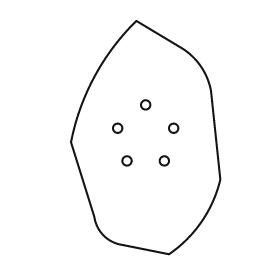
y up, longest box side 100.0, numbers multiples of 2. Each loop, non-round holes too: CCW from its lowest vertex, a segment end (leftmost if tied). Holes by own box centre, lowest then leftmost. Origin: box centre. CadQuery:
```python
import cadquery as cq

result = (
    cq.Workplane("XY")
    .moveTo(10.0, -50.0)
    .threePointArc((24.0, -36.0), (32.0, -18.0))
    .lineTo(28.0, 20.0)
    .threePointArc((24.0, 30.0), (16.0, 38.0))
    .lineTo(-4.0, 50.0)
    .threePointArc((-22.0, 26.0), (-32.0, -2.0))
    .lineTo(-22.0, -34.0)
    .threePointArc((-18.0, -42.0), (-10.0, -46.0))
    .close()
    .moveTo(-8.0, -10.0)
    .circle(2.0)
    .moveTo(8.0, -10.0)
    .circle(2.0)
    .moveTo(-12.0, 4.0)
    .circle(2.0)
    .moveTo(12.0, 4.0)
    .circle(2.0)
    .moveTo(0.0, 14.0)
    .circle(2.0)
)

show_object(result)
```